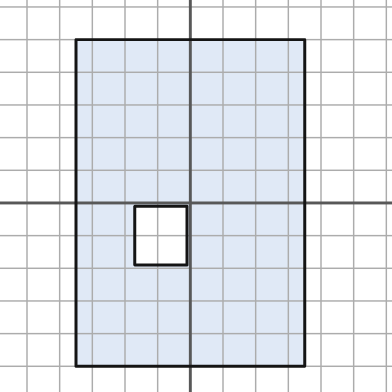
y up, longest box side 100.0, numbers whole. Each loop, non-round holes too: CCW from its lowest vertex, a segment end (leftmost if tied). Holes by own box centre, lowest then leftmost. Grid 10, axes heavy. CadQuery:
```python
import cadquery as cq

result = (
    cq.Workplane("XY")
    .moveTo(-35.0, -50.0)
    .lineTo(35.0, -50.0)
    .lineTo(35.0, 50.0)
    .lineTo(-35.0, 50.0)
    .close()
    .moveTo(-17.0, -19.0)
    .lineTo(-1.0, -19.0)
    .lineTo(-1.0, -1.0)
    .lineTo(-17.0, -1.0)
    .close()
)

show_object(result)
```